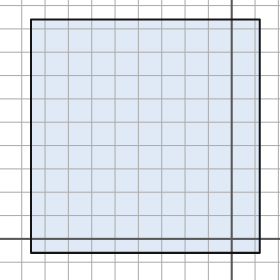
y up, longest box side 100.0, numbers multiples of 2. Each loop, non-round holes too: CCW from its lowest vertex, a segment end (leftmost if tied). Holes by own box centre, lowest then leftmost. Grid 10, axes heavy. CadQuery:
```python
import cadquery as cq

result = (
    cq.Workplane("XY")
    .moveTo(-86.0, -6.0)
    .lineTo(12.0, -6.0)
    .lineTo(12.0, 94.0)
    .lineTo(-86.0, 94.0)
    .close()
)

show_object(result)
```